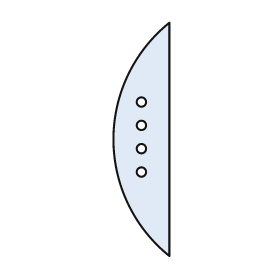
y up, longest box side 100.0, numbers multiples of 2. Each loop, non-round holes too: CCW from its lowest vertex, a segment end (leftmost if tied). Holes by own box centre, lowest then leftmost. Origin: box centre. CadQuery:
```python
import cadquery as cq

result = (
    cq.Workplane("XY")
    .moveTo(12.0, -50.0)
    .lineTo(12.0, 50.0)
    .threePointArc((-12.0, 0.0), (12.0, -50.0))
    .close()
    .moveTo(0.0, -14.0)
    .circle(2.0)
    .moveTo(0.0, -4.0)
    .circle(2.0)
    .moveTo(0.0, 6.0)
    .circle(2.0)
    .moveTo(0.0, 16.0)
    .circle(2.0)
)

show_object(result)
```